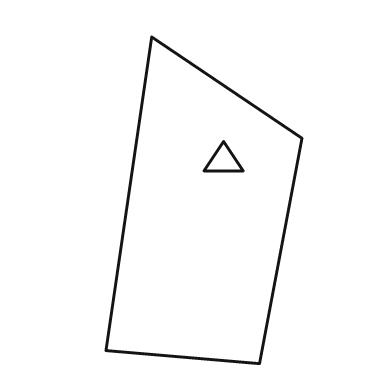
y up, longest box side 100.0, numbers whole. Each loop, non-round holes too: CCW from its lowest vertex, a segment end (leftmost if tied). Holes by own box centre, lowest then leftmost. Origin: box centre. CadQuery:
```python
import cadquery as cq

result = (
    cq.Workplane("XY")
    .moveTo(17.0, -50.0)
    .lineTo(30.0, 19.0)
    .lineTo(-16.0, 50.0)
    .lineTo(-30.0, -46.0)
    .close()
    .moveTo(0.0, 9.0)
    .lineTo(12.0, 9.0)
    .lineTo(6.0, 18.0)
    .close()
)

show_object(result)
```